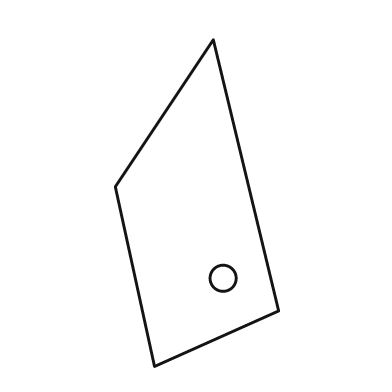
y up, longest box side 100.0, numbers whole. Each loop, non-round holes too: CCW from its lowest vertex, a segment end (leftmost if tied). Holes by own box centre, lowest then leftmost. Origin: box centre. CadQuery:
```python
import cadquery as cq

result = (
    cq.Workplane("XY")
    .moveTo(-13.0, -50.0)
    .lineTo(25.0, -33.0)
    .lineTo(5.0, 50.0)
    .lineTo(-25.0, 5.0)
    .close()
    .moveTo(8.0, -23.0)
    .circle(4.0)
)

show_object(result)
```